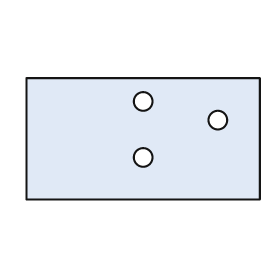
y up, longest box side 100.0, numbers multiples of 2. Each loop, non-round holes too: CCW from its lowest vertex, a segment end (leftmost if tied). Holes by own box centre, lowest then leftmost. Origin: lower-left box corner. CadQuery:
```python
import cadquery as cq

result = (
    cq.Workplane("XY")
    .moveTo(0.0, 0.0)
    .lineTo(100.0, 0.0)
    .lineTo(100.0, 52.0)
    .lineTo(0.0, 52.0)
    .close()
    .moveTo(50.0, 18.0)
    .circle(4.0)
    .moveTo(82.0, 34.0)
    .circle(4.0)
    .moveTo(50.0, 42.0)
    .circle(4.0)
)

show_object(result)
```